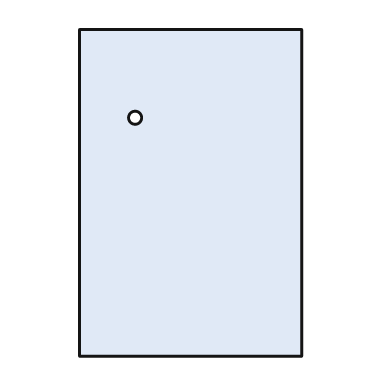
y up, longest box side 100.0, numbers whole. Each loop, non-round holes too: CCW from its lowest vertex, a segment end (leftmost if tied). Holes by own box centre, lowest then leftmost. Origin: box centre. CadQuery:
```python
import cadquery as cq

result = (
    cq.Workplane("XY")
    .moveTo(-34.0, -50.0)
    .lineTo(34.0, -50.0)
    .lineTo(34.0, 50.0)
    .lineTo(-34.0, 50.0)
    .close()
    .moveTo(-17.0, 23.0)
    .circle(2.0)
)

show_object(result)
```